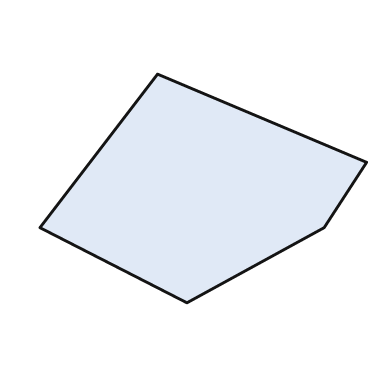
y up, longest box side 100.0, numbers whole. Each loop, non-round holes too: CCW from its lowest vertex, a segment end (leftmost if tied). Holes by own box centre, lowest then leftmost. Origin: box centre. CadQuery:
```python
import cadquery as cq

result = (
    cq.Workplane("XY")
    .moveTo(-5.0, -35.0)
    .lineTo(37.0, -12.0)
    .lineTo(50.0, 8.0)
    .lineTo(-14.0, 35.0)
    .lineTo(-50.0, -12.0)
    .close()
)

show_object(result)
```